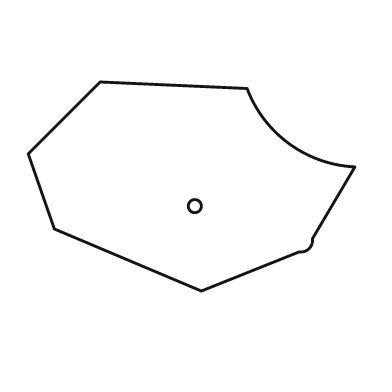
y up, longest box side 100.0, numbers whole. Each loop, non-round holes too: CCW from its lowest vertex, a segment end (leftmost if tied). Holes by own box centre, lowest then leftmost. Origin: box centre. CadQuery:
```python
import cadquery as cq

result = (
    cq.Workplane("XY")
    .moveTo(3.0, -32.0)
    .lineTo(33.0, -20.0)
    .threePointArc((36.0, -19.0), (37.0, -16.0))
    .lineTo(50.0, 6.0)
    .threePointArc((30.0, 13.0), (17.0, 30.0))
    .lineTo(-28.0, 32.0)
    .lineTo(-50.0, 10.0)
    .lineTo(-42.0, -13.0)
    .close()
    .moveTo(1.0, -6.0)
    .circle(2.0)
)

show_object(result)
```